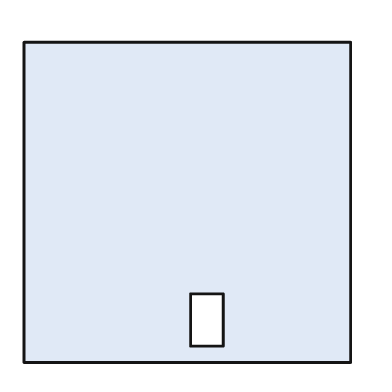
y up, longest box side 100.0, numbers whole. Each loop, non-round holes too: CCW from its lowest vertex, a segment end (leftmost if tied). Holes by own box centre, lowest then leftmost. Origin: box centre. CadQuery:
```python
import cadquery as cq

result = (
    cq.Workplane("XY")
    .moveTo(-50.0, -49.0)
    .lineTo(50.0, -49.0)
    .lineTo(50.0, 49.0)
    .lineTo(-50.0, 49.0)
    .close()
    .moveTo(1.0, -44.0)
    .lineTo(11.0, -44.0)
    .lineTo(11.0, -28.0)
    .lineTo(1.0, -28.0)
    .close()
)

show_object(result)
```